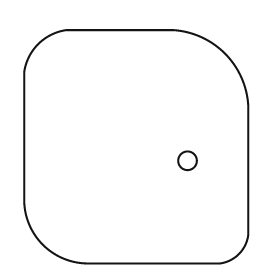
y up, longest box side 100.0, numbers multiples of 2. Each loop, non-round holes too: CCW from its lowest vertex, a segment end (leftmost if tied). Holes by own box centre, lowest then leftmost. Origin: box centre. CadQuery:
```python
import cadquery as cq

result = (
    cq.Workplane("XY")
    .moveTo(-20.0, -50.0)
    .lineTo(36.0, -50.0)
    .threePointArc((44.0, -46.0), (48.0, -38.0))
    .lineTo(48.0, 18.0)
    .threePointArc((38.0, 40.0), (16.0, 50.0))
    .lineTo(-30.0, 50.0)
    .threePointArc((-42.0, 44.0), (-48.0, 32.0))
    .lineTo(-48.0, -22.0)
    .threePointArc((-40.0, -42.0), (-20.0, -50.0))
    .close()
    .moveTo(22.0, -6.0)
    .circle(4.0)
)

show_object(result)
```